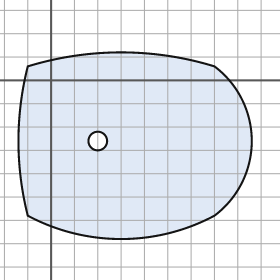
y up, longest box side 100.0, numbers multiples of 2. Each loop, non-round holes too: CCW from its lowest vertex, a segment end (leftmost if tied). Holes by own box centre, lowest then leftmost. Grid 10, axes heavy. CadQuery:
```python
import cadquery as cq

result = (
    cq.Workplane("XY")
    .moveTo(-10.0, -58.0)
    .threePointArc((30.0, -68.0), (70.0, -58.0))
    .threePointArc((86.0, -26.0), (70.0, 6.0))
    .threePointArc((30.0, 12.0), (-10.0, 6.0))
    .threePointArc((-14.0, -26.0), (-10.0, -58.0))
    .close()
    .moveTo(20.0, -26.0)
    .circle(4.0)
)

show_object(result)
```